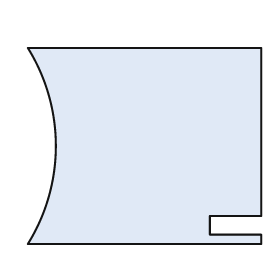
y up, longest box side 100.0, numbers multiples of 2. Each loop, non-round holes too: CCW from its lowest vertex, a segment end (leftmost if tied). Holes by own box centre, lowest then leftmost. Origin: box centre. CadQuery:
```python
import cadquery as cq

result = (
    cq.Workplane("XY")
    .moveTo(-50.0, -42.0)
    .lineTo(50.0, -42.0)
    .lineTo(50.0, -38.0)
    .lineTo(28.0, -38.0)
    .lineTo(28.0, -30.0)
    .lineTo(50.0, -30.0)
    .lineTo(50.0, 42.0)
    .lineTo(-50.0, 42.0)
    .threePointArc((-38.0, 0.0), (-50.0, -42.0))
    .close()
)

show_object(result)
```